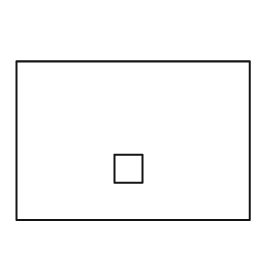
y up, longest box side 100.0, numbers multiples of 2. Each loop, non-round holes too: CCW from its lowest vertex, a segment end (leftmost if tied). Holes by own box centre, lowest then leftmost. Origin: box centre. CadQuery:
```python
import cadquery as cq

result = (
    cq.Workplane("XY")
    .moveTo(-50.0, -34.0)
    .lineTo(50.0, -34.0)
    .lineTo(50.0, 34.0)
    .lineTo(-50.0, 34.0)
    .close()
    .moveTo(-8.0, -18.0)
    .lineTo(4.0, -18.0)
    .lineTo(4.0, -6.0)
    .lineTo(-8.0, -6.0)
    .close()
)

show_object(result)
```